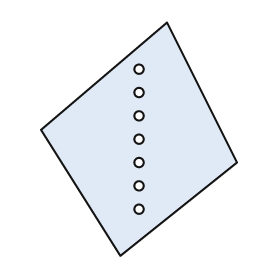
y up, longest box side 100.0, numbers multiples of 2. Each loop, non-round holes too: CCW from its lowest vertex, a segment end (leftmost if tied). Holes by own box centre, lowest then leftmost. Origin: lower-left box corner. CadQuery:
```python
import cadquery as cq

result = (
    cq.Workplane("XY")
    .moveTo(34.0, 0.0)
    .lineTo(84.0, 40.0)
    .lineTo(54.0, 100.0)
    .lineTo(0.0, 54.0)
    .close()
    .moveTo(42.0, 20.0)
    .circle(2.0)
    .moveTo(42.0, 30.0)
    .circle(2.0)
    .moveTo(42.0, 40.0)
    .circle(2.0)
    .moveTo(42.0, 50.0)
    .circle(2.0)
    .moveTo(42.0, 60.0)
    .circle(2.0)
    .moveTo(42.0, 70.0)
    .circle(2.0)
    .moveTo(42.0, 80.0)
    .circle(2.0)
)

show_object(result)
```